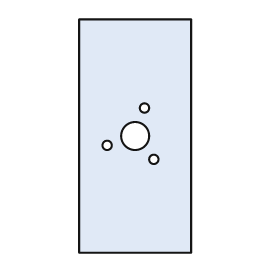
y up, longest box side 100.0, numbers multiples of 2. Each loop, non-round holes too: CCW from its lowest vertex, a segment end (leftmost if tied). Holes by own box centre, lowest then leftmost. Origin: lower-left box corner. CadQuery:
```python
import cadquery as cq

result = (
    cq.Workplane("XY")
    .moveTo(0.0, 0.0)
    .lineTo(48.0, 0.0)
    .lineTo(48.0, 100.0)
    .lineTo(0.0, 100.0)
    .close()
    .moveTo(32.0, 40.0)
    .circle(2.0)
    .moveTo(12.0, 46.0)
    .circle(2.0)
    .moveTo(24.0, 50.0)
    .circle(6.0)
    .moveTo(28.0, 62.0)
    .circle(2.0)
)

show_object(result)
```